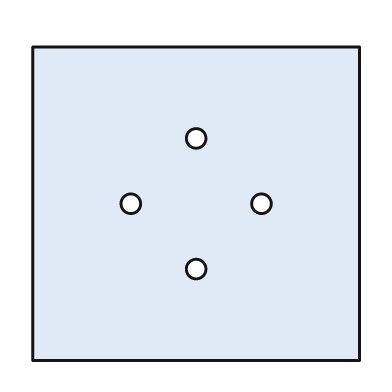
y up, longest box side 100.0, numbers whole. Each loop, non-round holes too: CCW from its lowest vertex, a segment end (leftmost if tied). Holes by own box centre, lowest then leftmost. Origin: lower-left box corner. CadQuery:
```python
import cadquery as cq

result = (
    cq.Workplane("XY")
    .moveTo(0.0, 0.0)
    .lineTo(100.0, 0.0)
    .lineTo(100.0, 96.0)
    .lineTo(0.0, 96.0)
    .close()
    .moveTo(50.0, 28.0)
    .circle(3.0)
    .moveTo(30.0, 48.0)
    .circle(3.0)
    .moveTo(70.0, 48.0)
    .circle(3.0)
    .moveTo(50.0, 68.0)
    .circle(3.0)
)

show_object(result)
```